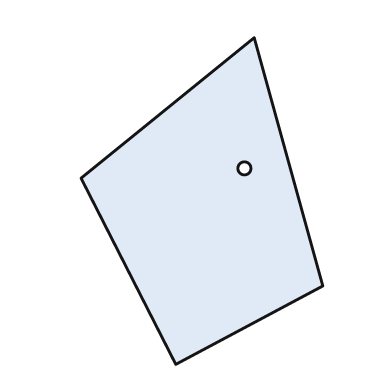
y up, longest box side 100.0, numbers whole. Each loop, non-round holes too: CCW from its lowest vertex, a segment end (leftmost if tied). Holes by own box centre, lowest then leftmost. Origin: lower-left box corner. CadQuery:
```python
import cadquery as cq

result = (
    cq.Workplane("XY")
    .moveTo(29.0, 0.0)
    .lineTo(74.0, 24.0)
    .lineTo(53.0, 100.0)
    .lineTo(0.0, 57.0)
    .close()
    .moveTo(50.0, 60.0)
    .circle(2.0)
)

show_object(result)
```